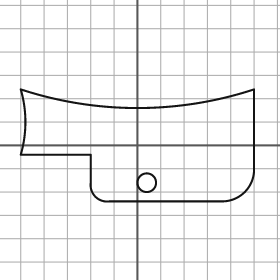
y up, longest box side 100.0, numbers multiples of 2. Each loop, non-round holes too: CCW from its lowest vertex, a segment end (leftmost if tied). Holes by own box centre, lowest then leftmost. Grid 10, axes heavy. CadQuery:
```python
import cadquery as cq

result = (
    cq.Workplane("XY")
    .moveTo(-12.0, -24.0)
    .lineTo(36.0, -24.0)
    .threePointArc((46.0, -20.0), (50.0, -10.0))
    .lineTo(50.0, 24.0)
    .threePointArc((0.0, 16.0), (-50.0, 24.0))
    .threePointArc((-48.0, 10.0), (-50.0, -4.0))
    .lineTo(-20.0, -4.0)
    .lineTo(-20.0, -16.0)
    .threePointArc((-18.0, -22.0), (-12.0, -24.0))
    .close()
    .moveTo(4.0, -16.0)
    .circle(4.0)
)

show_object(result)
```